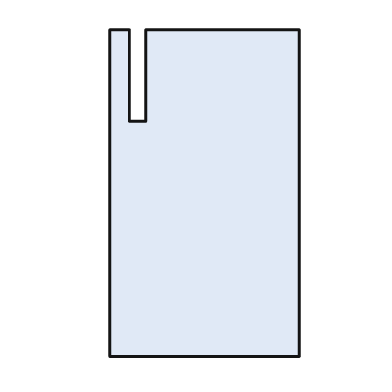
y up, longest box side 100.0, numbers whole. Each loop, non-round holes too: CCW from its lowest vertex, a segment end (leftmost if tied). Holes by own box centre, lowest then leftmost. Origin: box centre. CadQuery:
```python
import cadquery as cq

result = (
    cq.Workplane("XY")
    .moveTo(-29.0, -50.0)
    .lineTo(29.0, -50.0)
    .lineTo(29.0, 50.0)
    .lineTo(-18.0, 50.0)
    .lineTo(-18.0, 22.0)
    .lineTo(-23.0, 22.0)
    .lineTo(-23.0, 50.0)
    .lineTo(-29.0, 50.0)
    .close()
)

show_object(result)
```